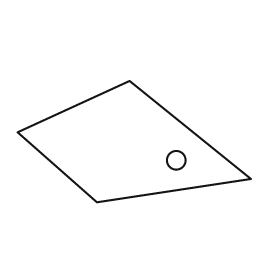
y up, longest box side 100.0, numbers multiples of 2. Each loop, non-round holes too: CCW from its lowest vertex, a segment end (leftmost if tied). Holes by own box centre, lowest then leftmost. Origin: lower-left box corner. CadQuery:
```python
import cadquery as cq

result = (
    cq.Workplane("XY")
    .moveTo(34.0, 0.0)
    .lineTo(100.0, 10.0)
    .lineTo(48.0, 52.0)
    .lineTo(0.0, 30.0)
    .close()
    .moveTo(68.0, 18.0)
    .circle(4.0)
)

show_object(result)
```